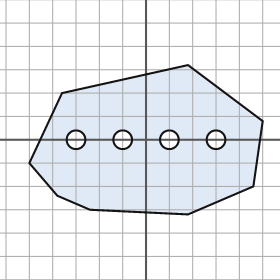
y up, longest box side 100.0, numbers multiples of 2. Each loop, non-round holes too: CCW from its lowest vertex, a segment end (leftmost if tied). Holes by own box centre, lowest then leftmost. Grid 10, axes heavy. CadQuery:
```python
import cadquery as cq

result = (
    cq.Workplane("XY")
    .moveTo(18.0, -32.0)
    .lineTo(46.0, -20.0)
    .lineTo(50.0, 8.0)
    .lineTo(18.0, 32.0)
    .lineTo(-36.0, 20.0)
    .lineTo(-50.0, -10.0)
    .lineTo(-38.0, -24.0)
    .lineTo(-24.0, -30.0)
    .close()
    .moveTo(-30.0, 0.0)
    .circle(4.0)
    .moveTo(-10.0, 0.0)
    .circle(4.0)
    .moveTo(10.0, 0.0)
    .circle(4.0)
    .moveTo(30.0, 0.0)
    .circle(4.0)
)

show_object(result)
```